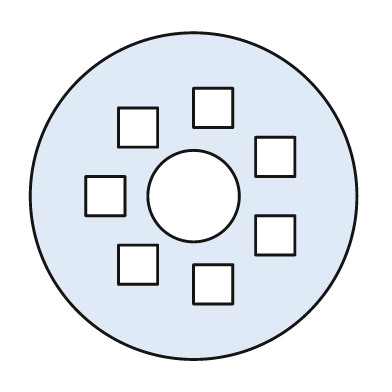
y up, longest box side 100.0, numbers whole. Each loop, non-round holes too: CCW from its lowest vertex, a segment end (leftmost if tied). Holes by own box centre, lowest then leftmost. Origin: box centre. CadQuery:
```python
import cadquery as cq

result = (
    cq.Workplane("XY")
    .moveTo(0.0, 0.0)
    .circle(50.0)
    .moveTo(0.0, -33.0)
    .lineTo(12.0, -33.0)
    .lineTo(12.0, -21.0)
    .lineTo(0.0, -21.0)
    .close()
    .moveTo(-23.0, -27.0)
    .lineTo(-11.0, -27.0)
    .lineTo(-11.0, -15.0)
    .lineTo(-23.0, -15.0)
    .close()
    .moveTo(19.0, -18.0)
    .lineTo(31.0, -18.0)
    .lineTo(31.0, -6.0)
    .lineTo(19.0, -6.0)
    .close()
    .moveTo(-33.0, -6.0)
    .lineTo(-21.0, -6.0)
    .lineTo(-21.0, 6.0)
    .lineTo(-33.0, 6.0)
    .close()
    .moveTo(0.0, 0.0)
    .circle(14.0)
    .moveTo(19.0, 6.0)
    .lineTo(31.0, 6.0)
    .lineTo(31.0, 18.0)
    .lineTo(19.0, 18.0)
    .close()
    .moveTo(-23.0, 15.0)
    .lineTo(-11.0, 15.0)
    .lineTo(-11.0, 27.0)
    .lineTo(-23.0, 27.0)
    .close()
    .moveTo(0.0, 21.0)
    .lineTo(12.0, 21.0)
    .lineTo(12.0, 33.0)
    .lineTo(0.0, 33.0)
    .close()
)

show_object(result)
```